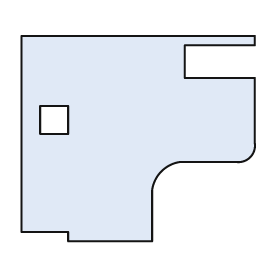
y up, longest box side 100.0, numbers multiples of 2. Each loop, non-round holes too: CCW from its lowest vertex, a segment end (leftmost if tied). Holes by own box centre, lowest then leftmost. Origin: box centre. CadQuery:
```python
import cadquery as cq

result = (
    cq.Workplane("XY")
    .moveTo(-30.0, -44.0)
    .lineTo(6.0, -44.0)
    .lineTo(6.0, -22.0)
    .threePointArc((10.0, -14.0), (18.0, -10.0))
    .lineTo(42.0, -10.0)
    .threePointArc((48.0, -8.0), (50.0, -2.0))
    .lineTo(50.0, 26.0)
    .lineTo(20.0, 26.0)
    .lineTo(20.0, 40.0)
    .lineTo(50.0, 40.0)
    .lineTo(50.0, 44.0)
    .lineTo(-50.0, 44.0)
    .lineTo(-50.0, -40.0)
    .lineTo(-30.0, -40.0)
    .close()
    .moveTo(-42.0, 2.0)
    .lineTo(-30.0, 2.0)
    .lineTo(-30.0, 14.0)
    .lineTo(-42.0, 14.0)
    .close()
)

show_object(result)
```